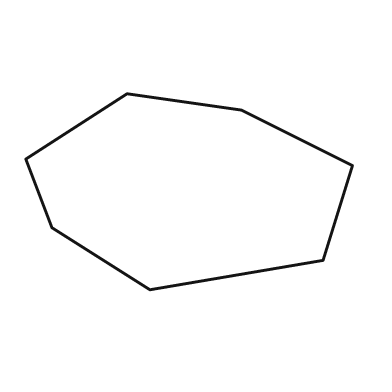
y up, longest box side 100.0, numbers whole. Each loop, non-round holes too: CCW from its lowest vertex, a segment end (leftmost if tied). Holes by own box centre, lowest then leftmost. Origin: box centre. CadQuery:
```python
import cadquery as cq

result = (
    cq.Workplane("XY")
    .moveTo(-12.0, -30.0)
    .lineTo(41.0, -21.0)
    .lineTo(50.0, 8.0)
    .lineTo(16.0, 25.0)
    .lineTo(-19.0, 30.0)
    .lineTo(-50.0, 10.0)
    .lineTo(-42.0, -11.0)
    .close()
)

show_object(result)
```